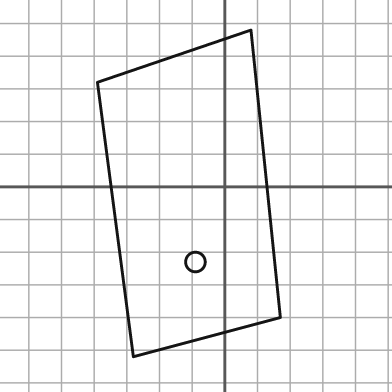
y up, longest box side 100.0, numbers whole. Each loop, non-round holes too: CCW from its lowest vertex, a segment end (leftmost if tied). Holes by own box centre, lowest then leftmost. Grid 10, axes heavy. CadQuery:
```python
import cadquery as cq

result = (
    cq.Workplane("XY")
    .moveTo(-28.0, -52.0)
    .lineTo(17.0, -40.0)
    .lineTo(8.0, 48.0)
    .lineTo(-39.0, 32.0)
    .close()
    .moveTo(-9.0, -23.0)
    .circle(3.0)
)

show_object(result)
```